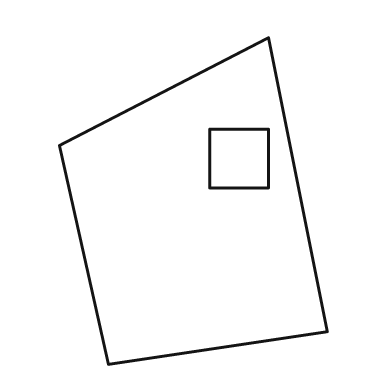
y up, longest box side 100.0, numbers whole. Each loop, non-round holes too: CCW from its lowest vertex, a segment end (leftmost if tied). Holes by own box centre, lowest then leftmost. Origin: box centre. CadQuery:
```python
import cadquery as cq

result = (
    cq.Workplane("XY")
    .moveTo(-26.0, -50.0)
    .lineTo(41.0, -40.0)
    .lineTo(23.0, 50.0)
    .lineTo(-41.0, 17.0)
    .close()
    .moveTo(5.0, 4.0)
    .lineTo(23.0, 4.0)
    .lineTo(23.0, 22.0)
    .lineTo(5.0, 22.0)
    .close()
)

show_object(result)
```